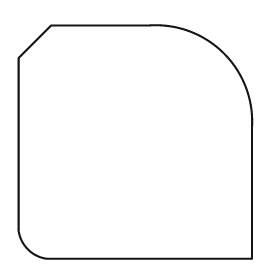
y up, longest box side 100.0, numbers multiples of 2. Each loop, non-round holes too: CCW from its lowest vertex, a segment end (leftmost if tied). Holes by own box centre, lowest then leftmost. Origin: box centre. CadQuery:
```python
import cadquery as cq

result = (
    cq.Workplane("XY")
    .moveTo(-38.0, -50.0)
    .lineTo(50.0, -50.0)
    .lineTo(50.0, 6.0)
    .threePointArc((38.0, 38.0), (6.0, 50.0))
    .lineTo(-36.0, 50.0)
    .lineTo(-50.0, 36.0)
    .lineTo(-50.0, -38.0)
    .threePointArc((-46.0, -46.0), (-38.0, -50.0))
    .close()
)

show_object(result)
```